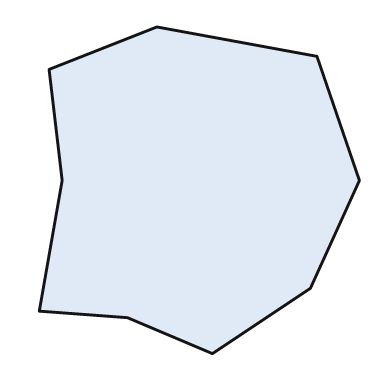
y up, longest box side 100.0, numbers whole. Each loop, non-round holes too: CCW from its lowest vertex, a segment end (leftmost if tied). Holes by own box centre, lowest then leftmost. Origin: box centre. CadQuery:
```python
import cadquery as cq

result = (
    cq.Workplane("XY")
    .moveTo(4.0, -50.0)
    .lineTo(34.0, -30.0)
    .lineTo(49.0, 3.0)
    .lineTo(36.0, 41.0)
    .lineTo(-13.0, 50.0)
    .lineTo(-46.0, 37.0)
    .lineTo(-42.0, 3.0)
    .lineTo(-49.0, -37.0)
    .lineTo(-22.0, -39.0)
    .close()
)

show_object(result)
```